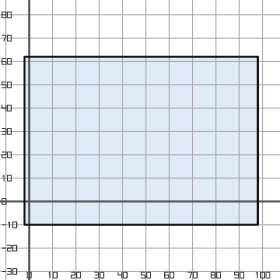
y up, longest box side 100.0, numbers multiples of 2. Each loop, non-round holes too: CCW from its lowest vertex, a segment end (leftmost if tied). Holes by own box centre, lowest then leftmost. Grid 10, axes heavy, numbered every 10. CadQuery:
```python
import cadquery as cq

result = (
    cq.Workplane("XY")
    .moveTo(-2.0, -10.0)
    .lineTo(98.0, -10.0)
    .lineTo(98.0, 62.0)
    .lineTo(-2.0, 62.0)
    .close()
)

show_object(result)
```